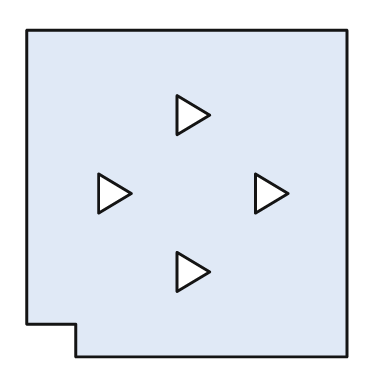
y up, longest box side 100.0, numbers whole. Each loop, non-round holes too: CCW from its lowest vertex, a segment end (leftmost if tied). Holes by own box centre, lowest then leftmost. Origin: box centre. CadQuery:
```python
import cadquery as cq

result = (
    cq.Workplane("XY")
    .moveTo(-34.0, -50.0)
    .lineTo(49.0, -50.0)
    .lineTo(49.0, 50.0)
    .lineTo(-49.0, 50.0)
    .lineTo(-49.0, -40.0)
    .lineTo(-34.0, -40.0)
    .close()
    .moveTo(-3.0, -30.0)
    .lineTo(7.0, -24.0)
    .lineTo(-3.0, -18.0)
    .close()
    .moveTo(-27.0, -6.0)
    .lineTo(-17.0, 0.0)
    .lineTo(-27.0, 6.0)
    .close()
    .moveTo(21.0, -6.0)
    .lineTo(31.0, 0.0)
    .lineTo(21.0, 6.0)
    .close()
    .moveTo(-3.0, 18.0)
    .lineTo(7.0, 24.0)
    .lineTo(-3.0, 30.0)
    .close()
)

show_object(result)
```